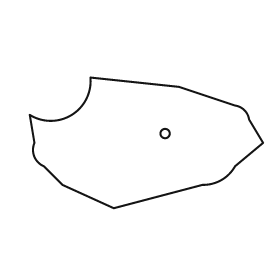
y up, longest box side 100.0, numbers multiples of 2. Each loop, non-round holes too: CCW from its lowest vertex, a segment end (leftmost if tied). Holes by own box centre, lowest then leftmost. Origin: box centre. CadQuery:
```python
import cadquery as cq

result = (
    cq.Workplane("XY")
    .moveTo(-14.0, -28.0)
    .lineTo(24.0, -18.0)
    .threePointArc((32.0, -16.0), (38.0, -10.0))
    .lineTo(50.0, 0.0)
    .lineTo(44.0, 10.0)
    .threePointArc((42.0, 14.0), (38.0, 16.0))
    .lineTo(14.0, 24.0)
    .lineTo(-24.0, 28.0)
    .threePointArc((-32.0, 12.0), (-50.0, 12.0))
    .lineTo(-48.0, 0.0)
    .threePointArc((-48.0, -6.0), (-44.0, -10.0))
    .lineTo(-36.0, -18.0)
    .close()
    .moveTo(8.0, 4.0)
    .circle(2.0)
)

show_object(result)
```